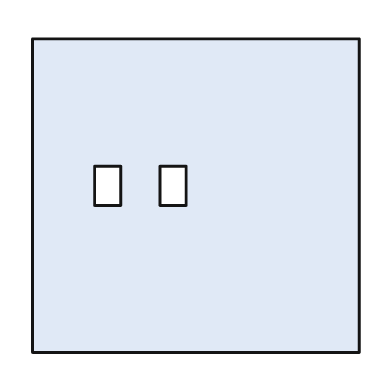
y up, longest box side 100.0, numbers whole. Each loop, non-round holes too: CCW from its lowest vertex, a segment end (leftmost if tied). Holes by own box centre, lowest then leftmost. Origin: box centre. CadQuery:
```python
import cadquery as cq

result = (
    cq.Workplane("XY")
    .moveTo(-50.0, -48.0)
    .lineTo(50.0, -48.0)
    .lineTo(50.0, 48.0)
    .lineTo(-50.0, 48.0)
    .close()
    .moveTo(-31.0, -3.0)
    .lineTo(-23.0, -3.0)
    .lineTo(-23.0, 9.0)
    .lineTo(-31.0, 9.0)
    .close()
    .moveTo(-11.0, -3.0)
    .lineTo(-3.0, -3.0)
    .lineTo(-3.0, 9.0)
    .lineTo(-11.0, 9.0)
    .close()
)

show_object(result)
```